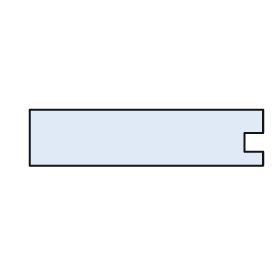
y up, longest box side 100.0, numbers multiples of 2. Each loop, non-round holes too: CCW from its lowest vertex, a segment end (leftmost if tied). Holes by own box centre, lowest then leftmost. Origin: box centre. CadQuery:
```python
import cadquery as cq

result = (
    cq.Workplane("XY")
    .moveTo(-50.0, -12.0)
    .lineTo(50.0, -12.0)
    .lineTo(50.0, -6.0)
    .lineTo(42.0, -6.0)
    .lineTo(42.0, 2.0)
    .lineTo(50.0, 2.0)
    .lineTo(50.0, 12.0)
    .lineTo(-50.0, 12.0)
    .close()
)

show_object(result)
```